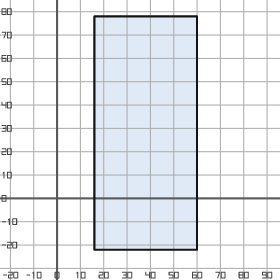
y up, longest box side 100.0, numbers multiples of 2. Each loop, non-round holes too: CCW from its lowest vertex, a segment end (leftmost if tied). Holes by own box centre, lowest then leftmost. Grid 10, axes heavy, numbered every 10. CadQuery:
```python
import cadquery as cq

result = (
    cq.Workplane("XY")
    .moveTo(16.0, -22.0)
    .lineTo(60.0, -22.0)
    .lineTo(60.0, 78.0)
    .lineTo(16.0, 78.0)
    .close()
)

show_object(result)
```